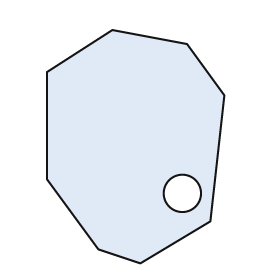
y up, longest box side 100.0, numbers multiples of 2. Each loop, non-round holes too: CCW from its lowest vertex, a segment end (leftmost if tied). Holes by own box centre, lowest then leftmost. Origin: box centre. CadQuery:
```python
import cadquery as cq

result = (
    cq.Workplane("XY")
    .moveTo(2.0, -50.0)
    .lineTo(32.0, -32.0)
    .lineTo(38.0, 22.0)
    .lineTo(22.0, 44.0)
    .lineTo(-10.0, 50.0)
    .lineTo(-38.0, 32.0)
    .lineTo(-38.0, -14.0)
    .lineTo(-16.0, -44.0)
    .close()
    .moveTo(20.0, -20.0)
    .circle(8.0)
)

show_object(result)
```